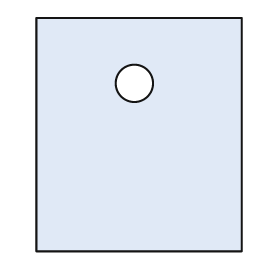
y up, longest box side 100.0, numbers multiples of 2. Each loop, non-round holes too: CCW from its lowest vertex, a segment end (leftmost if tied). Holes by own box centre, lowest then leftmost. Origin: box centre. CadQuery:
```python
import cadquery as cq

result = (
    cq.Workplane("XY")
    .moveTo(-44.0, -50.0)
    .lineTo(44.0, -50.0)
    .lineTo(44.0, 50.0)
    .lineTo(-44.0, 50.0)
    .close()
    .moveTo(-2.0, 22.0)
    .circle(8.0)
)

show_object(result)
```